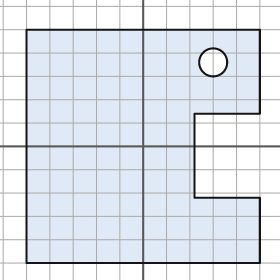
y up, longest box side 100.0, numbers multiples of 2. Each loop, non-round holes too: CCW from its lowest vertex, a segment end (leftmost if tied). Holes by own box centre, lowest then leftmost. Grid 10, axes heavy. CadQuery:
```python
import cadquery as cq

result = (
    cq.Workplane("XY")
    .moveTo(-50.0, -50.0)
    .lineTo(50.0, -50.0)
    .lineTo(50.0, -22.0)
    .lineTo(22.0, -22.0)
    .lineTo(22.0, 14.0)
    .lineTo(50.0, 14.0)
    .lineTo(50.0, 50.0)
    .lineTo(-50.0, 50.0)
    .close()
    .moveTo(30.0, 36.0)
    .circle(6.0)
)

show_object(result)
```